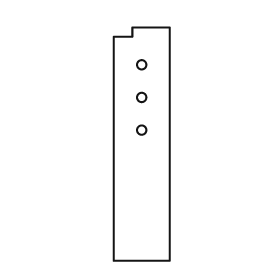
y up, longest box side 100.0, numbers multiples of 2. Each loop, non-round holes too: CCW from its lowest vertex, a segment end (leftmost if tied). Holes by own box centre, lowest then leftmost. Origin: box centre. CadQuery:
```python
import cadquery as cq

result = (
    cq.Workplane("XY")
    .moveTo(-12.0, -50.0)
    .lineTo(12.0, -50.0)
    .lineTo(12.0, 50.0)
    .lineTo(-4.0, 50.0)
    .lineTo(-4.0, 46.0)
    .lineTo(-12.0, 46.0)
    .close()
    .moveTo(0.0, 6.0)
    .circle(2.0)
    .moveTo(0.0, 20.0)
    .circle(2.0)
    .moveTo(0.0, 34.0)
    .circle(2.0)
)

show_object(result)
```